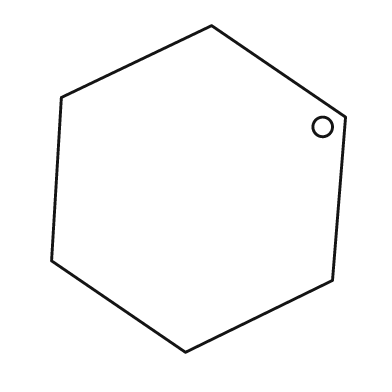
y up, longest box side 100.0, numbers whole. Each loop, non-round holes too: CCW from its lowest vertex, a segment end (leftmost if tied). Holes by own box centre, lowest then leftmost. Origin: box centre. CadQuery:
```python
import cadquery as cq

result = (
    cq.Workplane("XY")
    .moveTo(-4.0, -50.0)
    .lineTo(41.0, -28.0)
    .lineTo(45.0, 22.0)
    .lineTo(4.0, 50.0)
    .lineTo(-42.0, 28.0)
    .lineTo(-45.0, -22.0)
    .close()
    .moveTo(38.0, 19.0)
    .circle(3.0)
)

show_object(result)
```